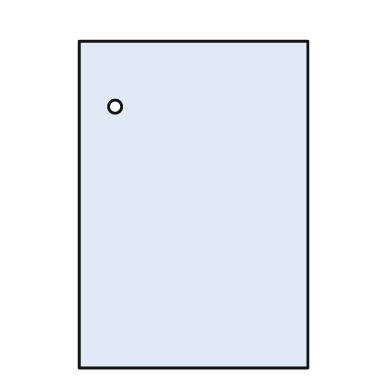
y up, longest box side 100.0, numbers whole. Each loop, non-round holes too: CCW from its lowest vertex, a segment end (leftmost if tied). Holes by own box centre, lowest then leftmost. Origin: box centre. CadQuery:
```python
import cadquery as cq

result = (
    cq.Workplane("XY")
    .moveTo(-35.0, -50.0)
    .lineTo(35.0, -50.0)
    .lineTo(35.0, 50.0)
    .lineTo(-35.0, 50.0)
    .close()
    .moveTo(-24.0, 30.0)
    .circle(2.0)
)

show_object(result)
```